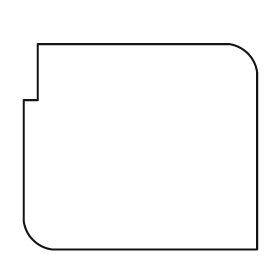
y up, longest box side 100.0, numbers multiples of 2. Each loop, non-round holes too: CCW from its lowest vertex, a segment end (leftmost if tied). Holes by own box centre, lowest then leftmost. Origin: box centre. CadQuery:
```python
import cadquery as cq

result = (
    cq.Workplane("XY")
    .moveTo(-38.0, -44.0)
    .lineTo(50.0, -44.0)
    .lineTo(50.0, 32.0)
    .threePointArc((46.0, 40.0), (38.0, 44.0))
    .lineTo(-44.0, 44.0)
    .lineTo(-44.0, 20.0)
    .lineTo(-50.0, 20.0)
    .lineTo(-50.0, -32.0)
    .threePointArc((-46.0, -40.0), (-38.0, -44.0))
    .close()
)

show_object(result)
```